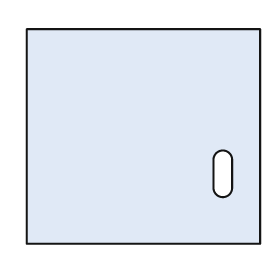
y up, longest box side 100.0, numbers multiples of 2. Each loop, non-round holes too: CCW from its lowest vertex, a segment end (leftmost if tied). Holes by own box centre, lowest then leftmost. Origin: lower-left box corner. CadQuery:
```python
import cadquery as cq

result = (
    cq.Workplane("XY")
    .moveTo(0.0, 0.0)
    .lineTo(100.0, 0.0)
    .lineTo(100.0, 92.0)
    .lineTo(0.0, 92.0)
    .close()
    .moveTo(80.0, 24.0)
    .threePointArc((84.0, 20.0), (88.0, 24.0))
    .lineTo(88.0, 36.0)
    .threePointArc((84.0, 40.0), (80.0, 36.0))
    .close()
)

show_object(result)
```